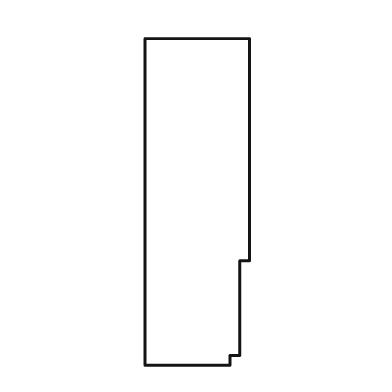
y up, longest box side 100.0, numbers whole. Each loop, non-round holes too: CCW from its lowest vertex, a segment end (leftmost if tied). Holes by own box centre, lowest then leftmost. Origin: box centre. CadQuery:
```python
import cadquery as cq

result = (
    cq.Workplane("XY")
    .moveTo(-16.0, -50.0)
    .lineTo(10.0, -50.0)
    .lineTo(10.0, -47.0)
    .lineTo(13.0, -47.0)
    .lineTo(13.0, -18.0)
    .lineTo(16.0, -18.0)
    .lineTo(16.0, 50.0)
    .lineTo(-16.0, 50.0)
    .close()
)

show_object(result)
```